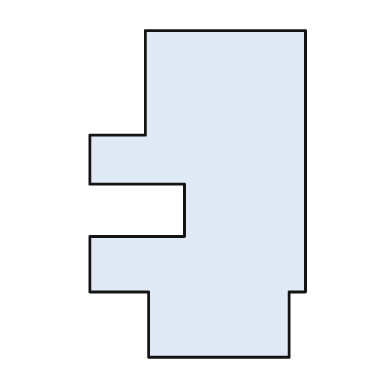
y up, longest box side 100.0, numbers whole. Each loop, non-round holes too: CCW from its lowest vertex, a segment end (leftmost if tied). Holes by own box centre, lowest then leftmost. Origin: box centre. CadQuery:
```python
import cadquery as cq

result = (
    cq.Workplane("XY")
    .moveTo(-15.0, -50.0)
    .lineTo(28.0, -50.0)
    .lineTo(28.0, -30.0)
    .lineTo(33.0, -30.0)
    .lineTo(33.0, 50.0)
    .lineTo(-16.0, 50.0)
    .lineTo(-16.0, 18.0)
    .lineTo(-33.0, 18.0)
    .lineTo(-33.0, 3.0)
    .lineTo(-4.0, 3.0)
    .lineTo(-4.0, -13.0)
    .lineTo(-33.0, -13.0)
    .lineTo(-33.0, -30.0)
    .lineTo(-15.0, -30.0)
    .close()
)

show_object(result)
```